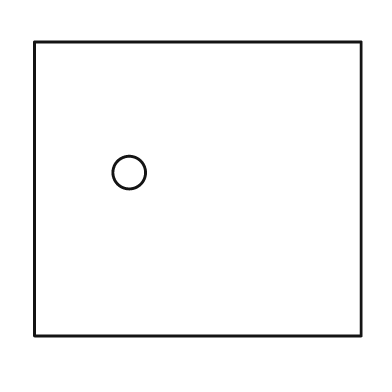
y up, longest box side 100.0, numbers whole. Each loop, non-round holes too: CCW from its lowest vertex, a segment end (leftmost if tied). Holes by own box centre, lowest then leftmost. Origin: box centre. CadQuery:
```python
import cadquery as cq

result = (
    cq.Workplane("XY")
    .moveTo(-50.0, -45.0)
    .lineTo(50.0, -45.0)
    .lineTo(50.0, 45.0)
    .lineTo(-50.0, 45.0)
    .close()
    .moveTo(-21.0, 5.0)
    .circle(5.0)
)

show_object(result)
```